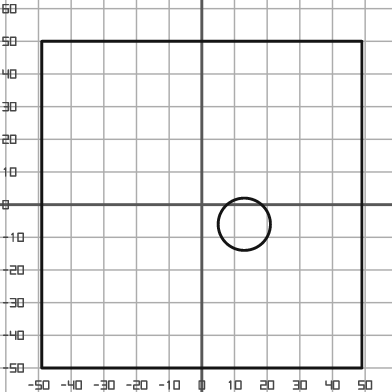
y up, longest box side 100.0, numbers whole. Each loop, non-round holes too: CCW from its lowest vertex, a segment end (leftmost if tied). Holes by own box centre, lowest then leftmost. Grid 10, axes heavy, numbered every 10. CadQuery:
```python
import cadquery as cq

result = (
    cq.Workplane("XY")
    .moveTo(-49.0, -50.0)
    .lineTo(49.0, -50.0)
    .lineTo(49.0, 50.0)
    .lineTo(-49.0, 50.0)
    .close()
    .moveTo(13.0, -6.0)
    .circle(8.0)
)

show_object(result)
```